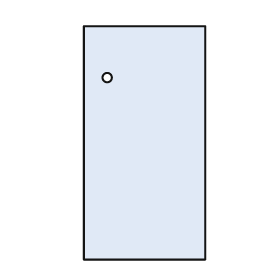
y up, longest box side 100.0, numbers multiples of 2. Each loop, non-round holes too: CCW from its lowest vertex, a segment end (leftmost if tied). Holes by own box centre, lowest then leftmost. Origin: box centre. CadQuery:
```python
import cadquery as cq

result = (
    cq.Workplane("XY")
    .moveTo(-26.0, -50.0)
    .lineTo(26.0, -50.0)
    .lineTo(26.0, 50.0)
    .lineTo(-26.0, 50.0)
    .close()
    .moveTo(-16.0, 28.0)
    .circle(2.0)
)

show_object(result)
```